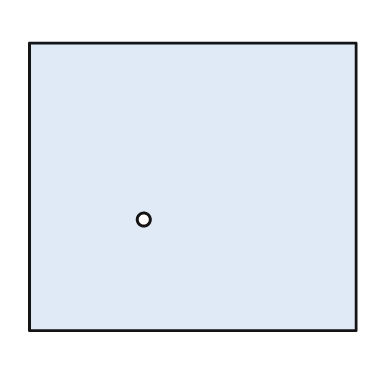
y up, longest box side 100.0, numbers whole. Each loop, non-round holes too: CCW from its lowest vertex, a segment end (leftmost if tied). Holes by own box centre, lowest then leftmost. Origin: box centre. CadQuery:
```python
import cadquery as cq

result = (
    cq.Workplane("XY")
    .moveTo(-50.0, -44.0)
    .lineTo(50.0, -44.0)
    .lineTo(50.0, 44.0)
    .lineTo(-50.0, 44.0)
    .close()
    .moveTo(-15.0, -10.0)
    .circle(2.0)
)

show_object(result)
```